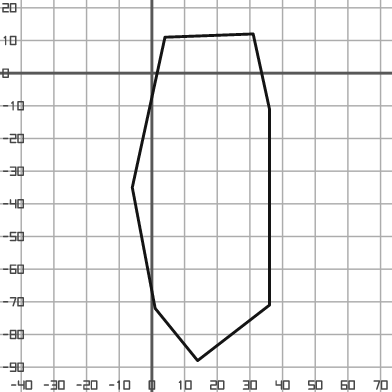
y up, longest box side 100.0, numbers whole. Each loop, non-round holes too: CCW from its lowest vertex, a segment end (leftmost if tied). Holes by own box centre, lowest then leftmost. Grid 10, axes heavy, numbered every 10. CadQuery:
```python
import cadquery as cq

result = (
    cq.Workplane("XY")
    .moveTo(14.0, -88.0)
    .lineTo(36.0, -71.0)
    .lineTo(36.0, -11.0)
    .lineTo(31.0, 12.0)
    .lineTo(4.0, 11.0)
    .lineTo(-6.0, -35.0)
    .lineTo(1.0, -72.0)
    .close()
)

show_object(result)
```